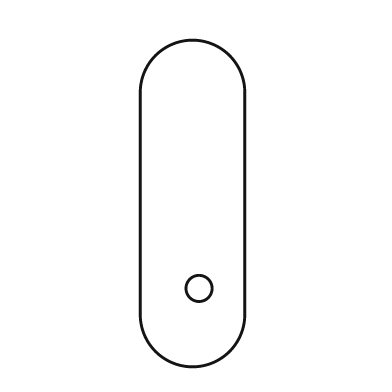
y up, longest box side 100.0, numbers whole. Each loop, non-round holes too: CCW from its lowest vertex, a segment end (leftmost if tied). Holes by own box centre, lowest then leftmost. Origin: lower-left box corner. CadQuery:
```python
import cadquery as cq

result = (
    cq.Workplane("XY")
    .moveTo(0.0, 16.0)
    .threePointArc((16.0, 0.0), (32.0, 16.0))
    .lineTo(32.0, 84.0)
    .threePointArc((16.0, 100.0), (0.0, 84.0))
    .close()
    .moveTo(18.0, 24.0)
    .circle(4.0)
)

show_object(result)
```